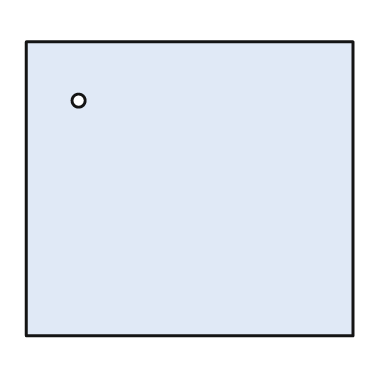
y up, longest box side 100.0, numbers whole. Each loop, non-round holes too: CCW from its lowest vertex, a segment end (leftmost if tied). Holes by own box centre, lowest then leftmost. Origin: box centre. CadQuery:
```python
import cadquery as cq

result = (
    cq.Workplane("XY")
    .moveTo(-50.0, -45.0)
    .lineTo(50.0, -45.0)
    .lineTo(50.0, 45.0)
    .lineTo(-50.0, 45.0)
    .close()
    .moveTo(-34.0, 27.0)
    .circle(2.0)
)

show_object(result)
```